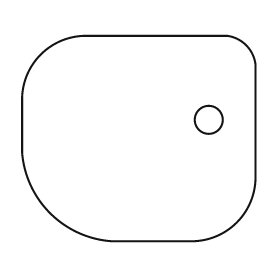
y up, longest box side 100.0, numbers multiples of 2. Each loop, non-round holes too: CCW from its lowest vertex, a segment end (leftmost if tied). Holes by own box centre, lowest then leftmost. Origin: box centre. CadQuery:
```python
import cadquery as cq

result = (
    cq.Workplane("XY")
    .moveTo(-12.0, -44.0)
    .lineTo(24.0, -44.0)
    .threePointArc((42.0, -36.0), (50.0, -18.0))
    .lineTo(50.0, 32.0)
    .threePointArc((46.0, 40.0), (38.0, 44.0))
    .lineTo(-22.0, 44.0)
    .threePointArc((-42.0, 36.0), (-50.0, 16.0))
    .lineTo(-50.0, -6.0)
    .threePointArc((-38.0, -32.0), (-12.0, -44.0))
    .close()
    .moveTo(30.0, 8.0)
    .circle(6.0)
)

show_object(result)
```